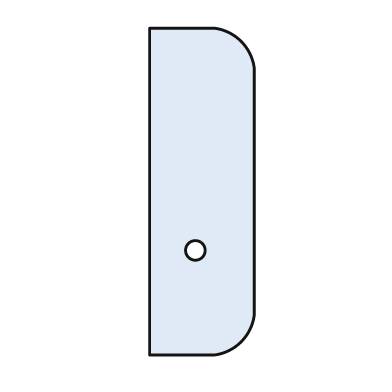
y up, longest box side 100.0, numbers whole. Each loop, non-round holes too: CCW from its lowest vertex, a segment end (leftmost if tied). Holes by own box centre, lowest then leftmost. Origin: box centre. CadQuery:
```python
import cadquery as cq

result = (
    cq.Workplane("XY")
    .moveTo(-16.0, -50.0)
    .lineTo(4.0, -50.0)
    .threePointArc((12.0, -46.0), (16.0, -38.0))
    .lineTo(16.0, 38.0)
    .threePointArc((12.0, 46.0), (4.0, 50.0))
    .lineTo(-16.0, 50.0)
    .close()
    .moveTo(-2.0, -18.0)
    .circle(3.0)
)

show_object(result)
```